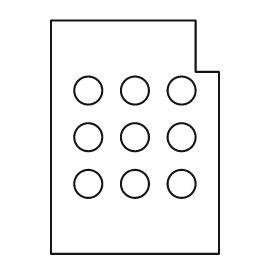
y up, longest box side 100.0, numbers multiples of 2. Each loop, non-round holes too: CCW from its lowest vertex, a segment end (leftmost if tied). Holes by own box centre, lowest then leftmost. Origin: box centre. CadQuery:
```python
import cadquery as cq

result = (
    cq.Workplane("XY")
    .moveTo(-36.0, -50.0)
    .lineTo(36.0, -50.0)
    .lineTo(36.0, 28.0)
    .lineTo(26.0, 28.0)
    .lineTo(26.0, 50.0)
    .lineTo(-36.0, 50.0)
    .close()
    .moveTo(-20.0, -20.0)
    .circle(6.0)
    .moveTo(0.0, -20.0)
    .circle(6.0)
    .moveTo(20.0, -20.0)
    .circle(6.0)
    .moveTo(-20.0, 0.0)
    .circle(6.0)
    .moveTo(0.0, 0.0)
    .circle(6.0)
    .moveTo(20.0, 0.0)
    .circle(6.0)
    .moveTo(-20.0, 20.0)
    .circle(6.0)
    .moveTo(0.0, 20.0)
    .circle(6.0)
    .moveTo(20.0, 20.0)
    .circle(6.0)
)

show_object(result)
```